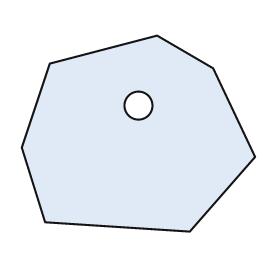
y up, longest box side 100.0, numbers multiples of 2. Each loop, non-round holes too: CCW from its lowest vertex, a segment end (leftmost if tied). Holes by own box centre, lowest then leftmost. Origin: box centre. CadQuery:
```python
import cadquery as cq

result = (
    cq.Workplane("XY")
    .moveTo(22.0, -42.0)
    .lineTo(50.0, -10.0)
    .lineTo(32.0, 28.0)
    .lineTo(8.0, 42.0)
    .lineTo(-38.0, 30.0)
    .lineTo(-50.0, -6.0)
    .lineTo(-40.0, -38.0)
    .close()
    .moveTo(0.0, 12.0)
    .circle(6.0)
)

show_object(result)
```